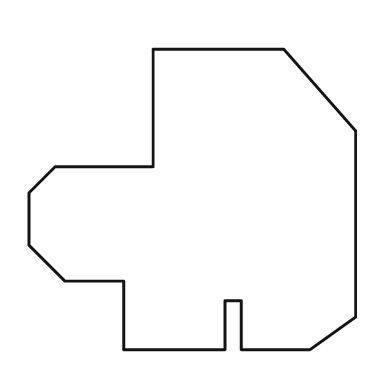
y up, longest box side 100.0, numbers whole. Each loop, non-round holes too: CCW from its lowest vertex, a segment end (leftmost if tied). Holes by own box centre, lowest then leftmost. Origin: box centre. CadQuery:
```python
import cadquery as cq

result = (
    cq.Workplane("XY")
    .moveTo(-21.0, -46.0)
    .lineTo(10.0, -46.0)
    .lineTo(10.0, -31.0)
    .lineTo(15.0, -31.0)
    .lineTo(15.0, -46.0)
    .lineTo(36.0, -46.0)
    .lineTo(50.0, -36.0)
    .lineTo(50.0, 21.0)
    .lineTo(28.0, 46.0)
    .lineTo(-12.0, 46.0)
    .lineTo(-12.0, 10.0)
    .lineTo(-42.0, 10.0)
    .lineTo(-50.0, 2.0)
    .lineTo(-50.0, -14.0)
    .lineTo(-39.0, -25.0)
    .lineTo(-21.0, -25.0)
    .close()
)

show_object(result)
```